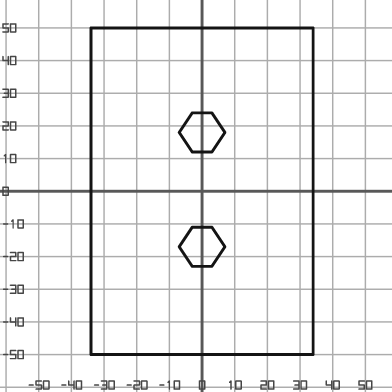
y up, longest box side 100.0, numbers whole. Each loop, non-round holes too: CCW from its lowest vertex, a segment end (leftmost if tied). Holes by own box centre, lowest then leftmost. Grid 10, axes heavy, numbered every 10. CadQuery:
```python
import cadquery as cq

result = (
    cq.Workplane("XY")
    .moveTo(-34.0, -50.0)
    .lineTo(34.0, -50.0)
    .lineTo(34.0, 50.0)
    .lineTo(-34.0, 50.0)
    .close()
    .moveTo(-3.0, -23.0)
    .lineTo(3.0, -23.0)
    .lineTo(7.0, -17.0)
    .lineTo(3.0, -11.0)
    .lineTo(-3.0, -11.0)
    .lineTo(-7.0, -17.0)
    .close()
    .moveTo(-3.0, 12.0)
    .lineTo(3.0, 12.0)
    .lineTo(7.0, 18.0)
    .lineTo(3.0, 24.0)
    .lineTo(-3.0, 24.0)
    .lineTo(-7.0, 18.0)
    .close()
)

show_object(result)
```